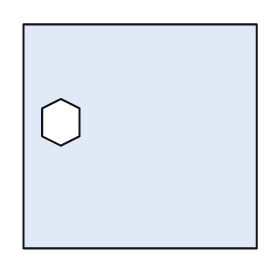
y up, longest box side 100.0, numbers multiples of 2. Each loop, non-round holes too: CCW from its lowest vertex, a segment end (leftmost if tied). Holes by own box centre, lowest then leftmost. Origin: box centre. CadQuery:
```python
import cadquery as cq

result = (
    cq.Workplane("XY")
    .moveTo(-50.0, -48.0)
    .lineTo(50.0, -48.0)
    .lineTo(50.0, 48.0)
    .lineTo(-50.0, 48.0)
    .close()
    .moveTo(-34.0, -4.0)
    .lineTo(-26.0, 0.0)
    .lineTo(-26.0, 12.0)
    .lineTo(-34.0, 16.0)
    .lineTo(-42.0, 12.0)
    .lineTo(-42.0, 0.0)
    .close()
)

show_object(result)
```